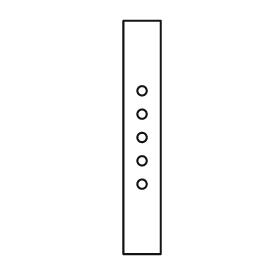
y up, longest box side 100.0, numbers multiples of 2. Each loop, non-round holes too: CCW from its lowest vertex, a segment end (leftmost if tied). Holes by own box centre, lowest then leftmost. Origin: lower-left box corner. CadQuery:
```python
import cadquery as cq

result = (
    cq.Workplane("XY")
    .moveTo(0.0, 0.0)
    .lineTo(16.0, 0.0)
    .lineTo(16.0, 100.0)
    .lineTo(0.0, 100.0)
    .close()
    .moveTo(8.0, 30.0)
    .circle(2.0)
    .moveTo(8.0, 40.0)
    .circle(2.0)
    .moveTo(8.0, 50.0)
    .circle(2.0)
    .moveTo(8.0, 60.0)
    .circle(2.0)
    .moveTo(8.0, 70.0)
    .circle(2.0)
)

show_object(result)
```